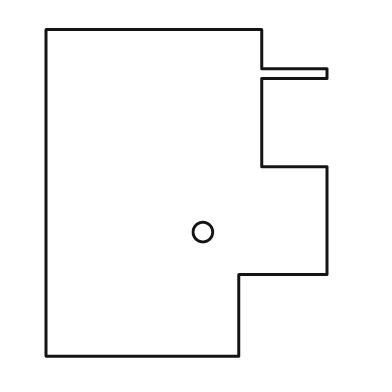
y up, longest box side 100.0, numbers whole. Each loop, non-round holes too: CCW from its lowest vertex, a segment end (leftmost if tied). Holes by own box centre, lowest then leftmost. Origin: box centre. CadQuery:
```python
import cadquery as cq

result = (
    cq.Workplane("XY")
    .moveTo(-43.0, -50.0)
    .lineTo(16.0, -50.0)
    .lineTo(16.0, -25.0)
    .lineTo(43.0, -25.0)
    .lineTo(43.0, 8.0)
    .lineTo(23.0, 8.0)
    .lineTo(23.0, 35.0)
    .lineTo(43.0, 35.0)
    .lineTo(43.0, 38.0)
    .lineTo(23.0, 38.0)
    .lineTo(23.0, 50.0)
    .lineTo(-43.0, 50.0)
    .close()
    .moveTo(5.0, -12.0)
    .circle(3.0)
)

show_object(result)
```